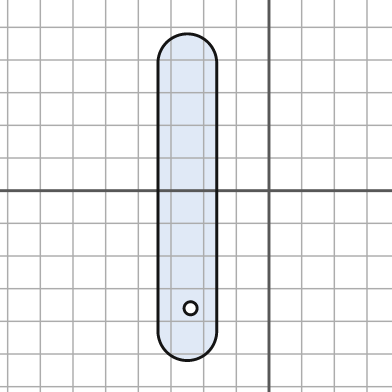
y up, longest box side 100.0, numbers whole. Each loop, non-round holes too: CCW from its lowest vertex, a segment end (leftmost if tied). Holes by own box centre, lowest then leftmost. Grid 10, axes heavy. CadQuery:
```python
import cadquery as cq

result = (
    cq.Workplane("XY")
    .moveTo(-34.0, -43.0)
    .threePointArc((-25.0, -52.0), (-16.0, -43.0))
    .lineTo(-16.0, 39.0)
    .threePointArc((-25.0, 48.0), (-34.0, 39.0))
    .close()
    .moveTo(-24.0, -36.0)
    .circle(2.0)
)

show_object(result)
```